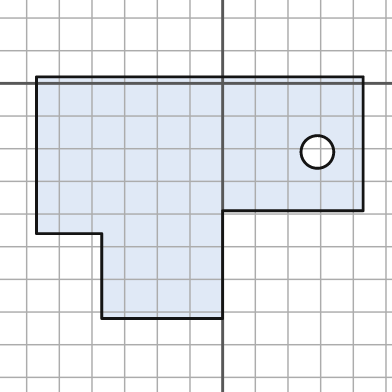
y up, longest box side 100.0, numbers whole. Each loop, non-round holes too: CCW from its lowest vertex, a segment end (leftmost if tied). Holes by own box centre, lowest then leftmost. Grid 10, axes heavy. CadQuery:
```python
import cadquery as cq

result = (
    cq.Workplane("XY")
    .moveTo(-37.0, -72.0)
    .lineTo(0.0, -72.0)
    .lineTo(0.0, -39.0)
    .lineTo(43.0, -39.0)
    .lineTo(43.0, 2.0)
    .lineTo(-57.0, 2.0)
    .lineTo(-57.0, -46.0)
    .lineTo(-37.0, -46.0)
    .close()
    .moveTo(29.0, -21.0)
    .circle(5.0)
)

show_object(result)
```